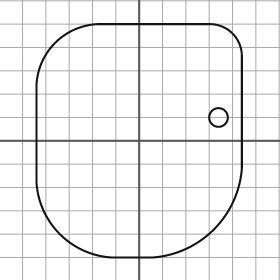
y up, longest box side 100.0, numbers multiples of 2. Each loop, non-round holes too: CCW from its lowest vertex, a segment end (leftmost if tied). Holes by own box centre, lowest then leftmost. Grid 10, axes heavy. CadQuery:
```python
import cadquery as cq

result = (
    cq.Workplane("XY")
    .moveTo(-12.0, -50.0)
    .lineTo(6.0, -50.0)
    .threePointArc((32.0, -38.0), (44.0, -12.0))
    .lineTo(44.0, 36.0)
    .threePointArc((40.0, 46.0), (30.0, 50.0))
    .lineTo(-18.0, 50.0)
    .threePointArc((-36.0, 42.0), (-44.0, 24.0))
    .lineTo(-44.0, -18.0)
    .threePointArc((-34.0, -40.0), (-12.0, -50.0))
    .close()
    .moveTo(34.0, 10.0)
    .circle(4.0)
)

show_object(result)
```